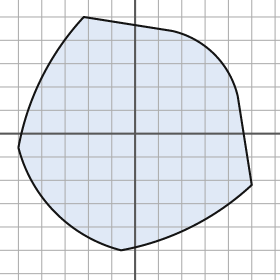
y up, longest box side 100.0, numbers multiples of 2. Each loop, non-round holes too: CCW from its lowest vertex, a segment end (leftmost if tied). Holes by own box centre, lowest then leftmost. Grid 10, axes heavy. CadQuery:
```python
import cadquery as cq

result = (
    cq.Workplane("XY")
    .moveTo(-6.0, -50.0)
    .threePointArc((24.0, -40.0), (50.0, -22.0))
    .lineTo(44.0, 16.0)
    .threePointArc((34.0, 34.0), (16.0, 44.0))
    .lineTo(-22.0, 50.0)
    .threePointArc((-40.0, 24.0), (-50.0, -6.0))
    .threePointArc((-34.0, -34.0), (-6.0, -50.0))
    .close()
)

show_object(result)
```